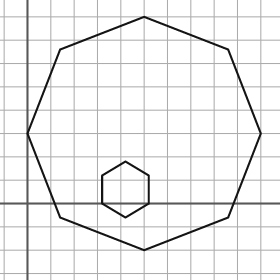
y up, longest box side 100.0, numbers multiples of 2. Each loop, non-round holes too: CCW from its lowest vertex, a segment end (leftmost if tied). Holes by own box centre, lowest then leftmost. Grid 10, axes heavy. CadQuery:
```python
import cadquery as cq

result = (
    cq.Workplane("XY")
    .moveTo(50.0, -20.0)
    .lineTo(86.0, -6.0)
    .lineTo(100.0, 30.0)
    .lineTo(86.0, 66.0)
    .lineTo(50.0, 80.0)
    .lineTo(14.0, 66.0)
    .lineTo(0.0, 30.0)
    .lineTo(14.0, -6.0)
    .close()
    .moveTo(42.0, -6.0)
    .lineTo(52.0, 0.0)
    .lineTo(52.0, 12.0)
    .lineTo(42.0, 18.0)
    .lineTo(32.0, 12.0)
    .lineTo(32.0, 0.0)
    .close()
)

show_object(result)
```